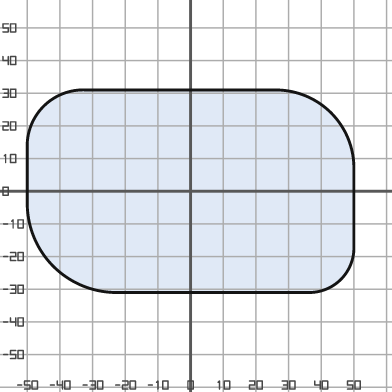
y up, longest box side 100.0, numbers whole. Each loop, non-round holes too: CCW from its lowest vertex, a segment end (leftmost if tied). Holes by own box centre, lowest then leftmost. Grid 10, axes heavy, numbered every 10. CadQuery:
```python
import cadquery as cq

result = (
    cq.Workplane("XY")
    .moveTo(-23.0, -31.0)
    .lineTo(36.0, -31.0)
    .threePointArc((46.0, -27.0), (50.0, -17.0))
    .lineTo(50.0, 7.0)
    .threePointArc((43.0, 24.0), (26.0, 31.0))
    .lineTo(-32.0, 31.0)
    .threePointArc((-45.0, 26.0), (-50.0, 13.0))
    .lineTo(-50.0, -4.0)
    .threePointArc((-42.0, -23.0), (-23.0, -31.0))
    .close()
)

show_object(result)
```